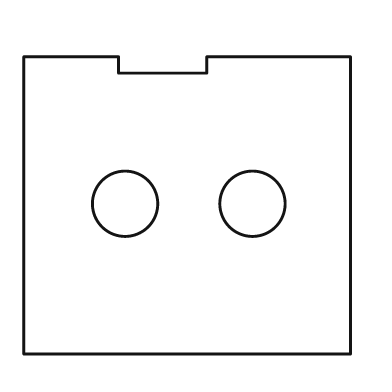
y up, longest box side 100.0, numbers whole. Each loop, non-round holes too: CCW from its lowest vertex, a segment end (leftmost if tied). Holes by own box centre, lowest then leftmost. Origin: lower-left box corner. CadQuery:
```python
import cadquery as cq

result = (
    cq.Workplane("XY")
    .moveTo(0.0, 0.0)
    .lineTo(100.0, 0.0)
    .lineTo(100.0, 91.0)
    .lineTo(56.0, 91.0)
    .lineTo(56.0, 86.0)
    .lineTo(29.0, 86.0)
    .lineTo(29.0, 91.0)
    .lineTo(0.0, 91.0)
    .close()
    .moveTo(31.0, 46.0)
    .circle(10.0)
    .moveTo(70.0, 46.0)
    .circle(10.0)
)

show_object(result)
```